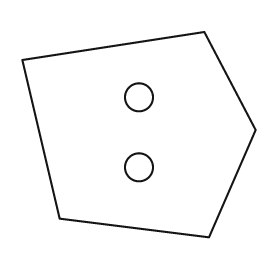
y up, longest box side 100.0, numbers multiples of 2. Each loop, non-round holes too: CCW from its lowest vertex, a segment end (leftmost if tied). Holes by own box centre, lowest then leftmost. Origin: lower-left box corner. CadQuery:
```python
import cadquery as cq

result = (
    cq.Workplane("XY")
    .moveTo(80.0, 0.0)
    .lineTo(100.0, 46.0)
    .lineTo(78.0, 88.0)
    .lineTo(0.0, 76.0)
    .lineTo(16.0, 8.0)
    .close()
    .moveTo(50.0, 30.0)
    .circle(6.0)
    .moveTo(50.0, 60.0)
    .circle(6.0)
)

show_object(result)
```